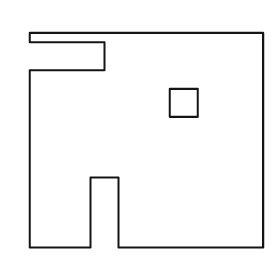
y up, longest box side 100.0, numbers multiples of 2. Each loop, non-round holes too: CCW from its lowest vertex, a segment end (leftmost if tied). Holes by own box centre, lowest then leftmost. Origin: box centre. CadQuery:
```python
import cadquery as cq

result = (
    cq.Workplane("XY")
    .moveTo(-50.0, -46.0)
    .lineTo(-24.0, -46.0)
    .lineTo(-24.0, -16.0)
    .lineTo(-12.0, -16.0)
    .lineTo(-12.0, -46.0)
    .lineTo(50.0, -46.0)
    .lineTo(50.0, 46.0)
    .lineTo(-50.0, 46.0)
    .lineTo(-50.0, 42.0)
    .lineTo(-18.0, 42.0)
    .lineTo(-18.0, 30.0)
    .lineTo(-50.0, 30.0)
    .close()
    .moveTo(10.0, 10.0)
    .lineTo(22.0, 10.0)
    .lineTo(22.0, 22.0)
    .lineTo(10.0, 22.0)
    .close()
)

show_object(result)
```